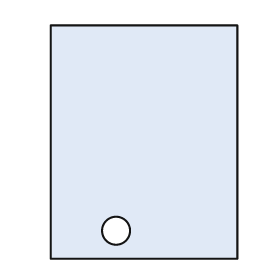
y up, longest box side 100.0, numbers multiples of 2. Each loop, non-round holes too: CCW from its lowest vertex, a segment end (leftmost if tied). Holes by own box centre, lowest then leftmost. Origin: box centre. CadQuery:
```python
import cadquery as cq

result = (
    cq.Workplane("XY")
    .moveTo(-40.0, -50.0)
    .lineTo(40.0, -50.0)
    .lineTo(40.0, 50.0)
    .lineTo(-40.0, 50.0)
    .close()
    .moveTo(-12.0, -38.0)
    .circle(6.0)
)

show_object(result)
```